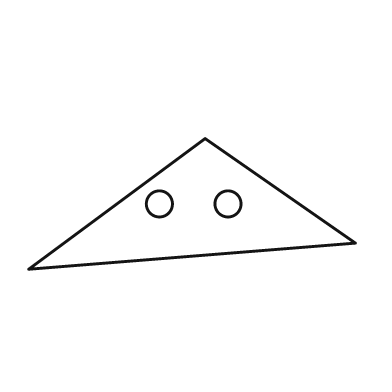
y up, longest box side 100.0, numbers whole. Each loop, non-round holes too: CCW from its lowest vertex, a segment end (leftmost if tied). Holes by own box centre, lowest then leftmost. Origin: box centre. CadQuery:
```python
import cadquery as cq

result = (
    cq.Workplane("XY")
    .moveTo(-50.0, -20.0)
    .lineTo(50.0, -12.0)
    .lineTo(4.0, 20.0)
    .close()
    .moveTo(-10.0, 0.0)
    .circle(4.0)
    .moveTo(11.0, 0.0)
    .circle(4.0)
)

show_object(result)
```